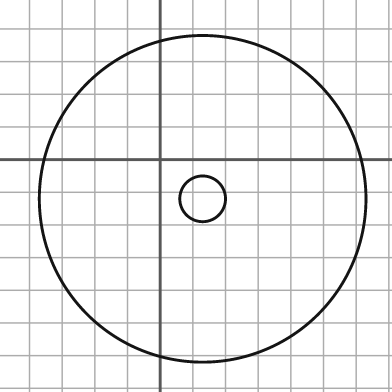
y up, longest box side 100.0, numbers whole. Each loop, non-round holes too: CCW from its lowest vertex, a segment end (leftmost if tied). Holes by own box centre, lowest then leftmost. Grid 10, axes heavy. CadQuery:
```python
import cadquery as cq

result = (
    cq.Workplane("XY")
    .moveTo(13.0, -12.0)
    .circle(50.0)
    .moveTo(13.0, -12.0)
    .circle(7.0)
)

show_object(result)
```